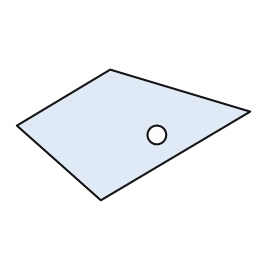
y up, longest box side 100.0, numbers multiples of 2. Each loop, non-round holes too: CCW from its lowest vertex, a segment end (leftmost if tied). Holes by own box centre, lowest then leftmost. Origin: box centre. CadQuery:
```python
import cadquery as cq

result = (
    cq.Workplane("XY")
    .moveTo(-14.0, -28.0)
    .lineTo(50.0, 10.0)
    .lineTo(-10.0, 28.0)
    .lineTo(-50.0, 4.0)
    .close()
    .moveTo(10.0, 0.0)
    .circle(4.0)
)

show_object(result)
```